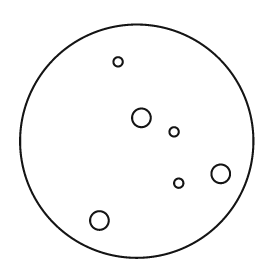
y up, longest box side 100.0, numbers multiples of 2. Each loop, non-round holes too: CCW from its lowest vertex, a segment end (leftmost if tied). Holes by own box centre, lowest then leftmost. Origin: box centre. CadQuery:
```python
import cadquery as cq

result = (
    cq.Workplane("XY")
    .moveTo(0.0, 0.0)
    .circle(50.0)
    .moveTo(-16.0, -34.0)
    .circle(4.0)
    .moveTo(18.0, -18.0)
    .circle(2.0)
    .moveTo(36.0, -14.0)
    .circle(4.0)
    .moveTo(16.0, 4.0)
    .circle(2.0)
    .moveTo(2.0, 10.0)
    .circle(4.0)
    .moveTo(-8.0, 34.0)
    .circle(2.0)
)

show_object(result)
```